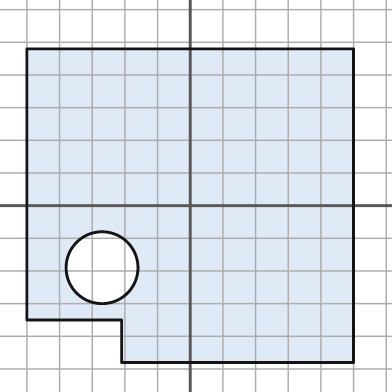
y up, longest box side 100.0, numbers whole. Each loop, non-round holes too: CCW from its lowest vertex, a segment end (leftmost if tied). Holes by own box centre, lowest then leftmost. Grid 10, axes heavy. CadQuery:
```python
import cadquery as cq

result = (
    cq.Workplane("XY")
    .moveTo(-21.0, -48.0)
    .lineTo(50.0, -48.0)
    .lineTo(50.0, 48.0)
    .lineTo(-50.0, 48.0)
    .lineTo(-50.0, -35.0)
    .lineTo(-21.0, -35.0)
    .close()
    .moveTo(-27.0, -19.0)
    .circle(11.0)
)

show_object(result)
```